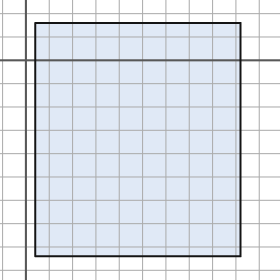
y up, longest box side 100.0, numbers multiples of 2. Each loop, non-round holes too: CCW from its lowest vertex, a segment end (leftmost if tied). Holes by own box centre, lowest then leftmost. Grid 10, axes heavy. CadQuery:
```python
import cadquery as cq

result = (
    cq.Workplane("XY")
    .moveTo(4.0, -84.0)
    .lineTo(92.0, -84.0)
    .lineTo(92.0, 16.0)
    .lineTo(4.0, 16.0)
    .close()
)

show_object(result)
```